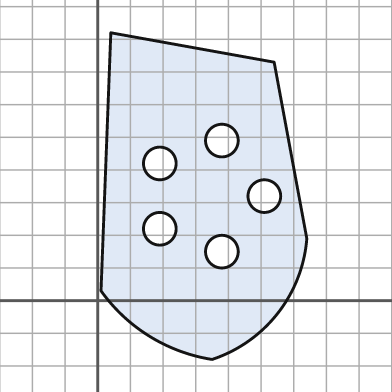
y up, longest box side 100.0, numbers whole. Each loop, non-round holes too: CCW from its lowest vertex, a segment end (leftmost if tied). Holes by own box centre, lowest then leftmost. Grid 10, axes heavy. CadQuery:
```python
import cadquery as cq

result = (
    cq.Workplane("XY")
    .moveTo(35.0, -18.0)
    .threePointArc((55.0, -4.0), (64.0, 19.0))
    .lineTo(54.0, 73.0)
    .lineTo(4.0, 82.0)
    .lineTo(1.0, 3.0)
    .threePointArc((16.0, -11.0), (35.0, -18.0))
    .close()
    .moveTo(38.0, 15.0)
    .circle(5.0)
    .moveTo(19.0, 22.0)
    .circle(5.0)
    .moveTo(51.0, 32.0)
    .circle(5.0)
    .moveTo(19.0, 42.0)
    .circle(5.0)
    .moveTo(38.0, 49.0)
    .circle(5.0)
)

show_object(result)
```